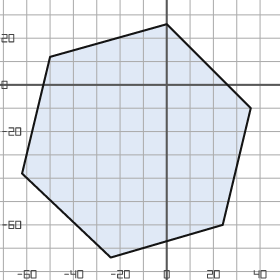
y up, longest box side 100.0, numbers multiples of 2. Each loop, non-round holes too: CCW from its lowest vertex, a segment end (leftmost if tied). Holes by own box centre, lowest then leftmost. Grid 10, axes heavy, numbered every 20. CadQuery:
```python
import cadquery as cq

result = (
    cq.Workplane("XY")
    .moveTo(-24.0, -74.0)
    .lineTo(24.0, -60.0)
    .lineTo(36.0, -10.0)
    .lineTo(0.0, 26.0)
    .lineTo(-50.0, 12.0)
    .lineTo(-62.0, -38.0)
    .close()
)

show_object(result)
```